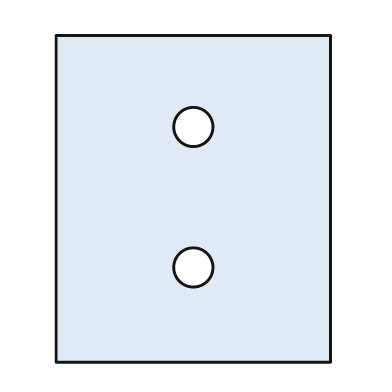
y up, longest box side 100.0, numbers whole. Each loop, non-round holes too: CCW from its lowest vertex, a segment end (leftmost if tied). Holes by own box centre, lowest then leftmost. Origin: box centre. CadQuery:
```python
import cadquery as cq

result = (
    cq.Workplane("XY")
    .moveTo(-42.0, -50.0)
    .lineTo(42.0, -50.0)
    .lineTo(42.0, 50.0)
    .lineTo(-42.0, 50.0)
    .close()
    .moveTo(0.0, -21.0)
    .circle(6.0)
    .moveTo(0.0, 22.0)
    .circle(6.0)
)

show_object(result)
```